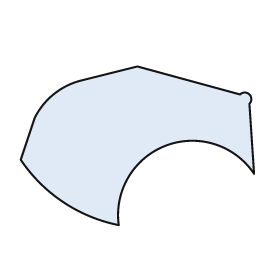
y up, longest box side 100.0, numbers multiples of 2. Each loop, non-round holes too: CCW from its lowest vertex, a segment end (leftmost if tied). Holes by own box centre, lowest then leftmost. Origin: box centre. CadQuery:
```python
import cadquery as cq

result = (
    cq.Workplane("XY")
    .moveTo(-8.0, -34.0)
    .threePointArc((12.0, 0.0), (50.0, -12.0))
    .lineTo(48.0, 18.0)
    .threePointArc((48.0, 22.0), (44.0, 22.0))
    .lineTo(0.0, 34.0)
    .lineTo(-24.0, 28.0)
    .threePointArc((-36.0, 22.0), (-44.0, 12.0))
    .lineTo(-50.0, -6.0)
    .threePointArc((-32.0, -24.0), (-8.0, -34.0))
    .close()
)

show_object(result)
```